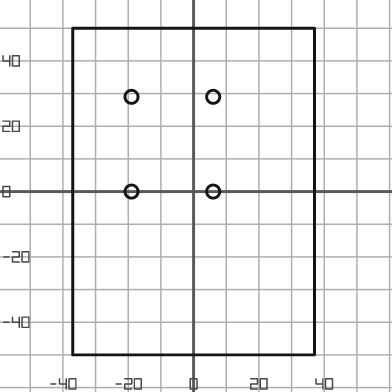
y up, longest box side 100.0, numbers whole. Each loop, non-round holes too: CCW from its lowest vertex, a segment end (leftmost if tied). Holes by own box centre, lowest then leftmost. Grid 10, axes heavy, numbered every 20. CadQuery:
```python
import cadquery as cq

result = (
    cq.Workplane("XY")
    .moveTo(-37.0, -50.0)
    .lineTo(37.0, -50.0)
    .lineTo(37.0, 50.0)
    .lineTo(-37.0, 50.0)
    .close()
    .moveTo(-19.0, 0.0)
    .circle(2.0)
    .moveTo(6.0, 0.0)
    .circle(2.0)
    .moveTo(-19.0, 29.0)
    .circle(2.0)
    .moveTo(6.0, 29.0)
    .circle(2.0)
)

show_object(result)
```